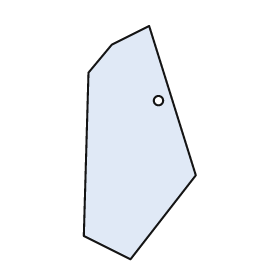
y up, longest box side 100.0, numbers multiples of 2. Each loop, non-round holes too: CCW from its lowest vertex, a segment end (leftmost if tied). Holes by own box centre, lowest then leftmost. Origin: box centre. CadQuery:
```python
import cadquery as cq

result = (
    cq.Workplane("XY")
    .moveTo(-4.0, -50.0)
    .lineTo(24.0, -14.0)
    .lineTo(4.0, 50.0)
    .lineTo(-12.0, 42.0)
    .lineTo(-22.0, 30.0)
    .lineTo(-24.0, -40.0)
    .close()
    .moveTo(8.0, 18.0)
    .circle(2.0)
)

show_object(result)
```